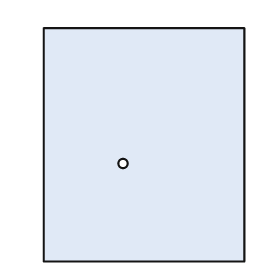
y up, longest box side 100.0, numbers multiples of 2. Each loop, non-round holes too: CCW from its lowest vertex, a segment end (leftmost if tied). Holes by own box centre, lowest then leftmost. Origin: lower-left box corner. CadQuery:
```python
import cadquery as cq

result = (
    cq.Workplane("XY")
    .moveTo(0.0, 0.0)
    .lineTo(86.0, 0.0)
    .lineTo(86.0, 100.0)
    .lineTo(0.0, 100.0)
    .close()
    .moveTo(34.0, 42.0)
    .circle(2.0)
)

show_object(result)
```